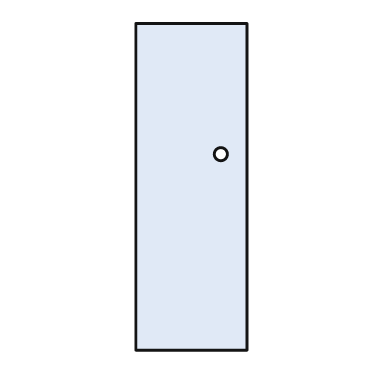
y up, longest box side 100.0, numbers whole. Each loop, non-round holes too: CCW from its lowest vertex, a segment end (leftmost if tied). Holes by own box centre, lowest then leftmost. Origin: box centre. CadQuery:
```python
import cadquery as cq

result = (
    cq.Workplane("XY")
    .moveTo(-17.0, -50.0)
    .lineTo(17.0, -50.0)
    .lineTo(17.0, 50.0)
    .lineTo(-17.0, 50.0)
    .close()
    .moveTo(9.0, 10.0)
    .circle(2.0)
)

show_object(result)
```